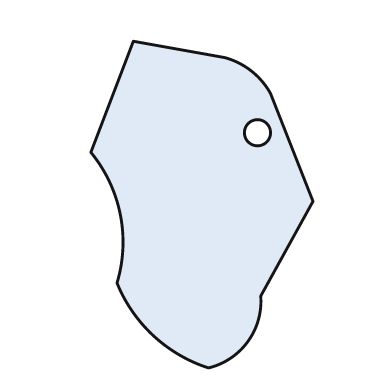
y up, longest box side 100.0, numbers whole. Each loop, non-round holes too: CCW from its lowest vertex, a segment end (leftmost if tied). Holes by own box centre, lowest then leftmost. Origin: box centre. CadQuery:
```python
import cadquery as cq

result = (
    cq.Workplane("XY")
    .moveTo(2.0, -50.0)
    .threePointArc((14.0, -42.0), (18.0, -28.0))
    .lineTo(34.0, 1.0)
    .lineTo(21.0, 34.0)
    .threePointArc((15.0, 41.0), (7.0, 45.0))
    .lineTo(-21.0, 50.0)
    .lineTo(-34.0, 16.0)
    .threePointArc((-25.0, -3.0), (-26.0, -24.0))
    .threePointArc((-15.0, -40.0), (2.0, -50.0))
    .close()
    .moveTo(17.0, 22.0)
    .circle(4.0)
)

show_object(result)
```